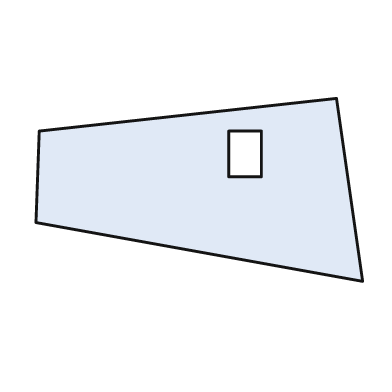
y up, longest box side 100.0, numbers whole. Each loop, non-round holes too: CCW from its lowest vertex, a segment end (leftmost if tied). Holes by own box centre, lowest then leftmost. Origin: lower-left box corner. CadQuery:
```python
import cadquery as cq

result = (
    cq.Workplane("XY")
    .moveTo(100.0, 0.0)
    .lineTo(92.0, 56.0)
    .lineTo(1.0, 46.0)
    .lineTo(0.0, 18.0)
    .close()
    .moveTo(59.0, 32.0)
    .lineTo(69.0, 32.0)
    .lineTo(69.0, 46.0)
    .lineTo(59.0, 46.0)
    .close()
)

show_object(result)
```